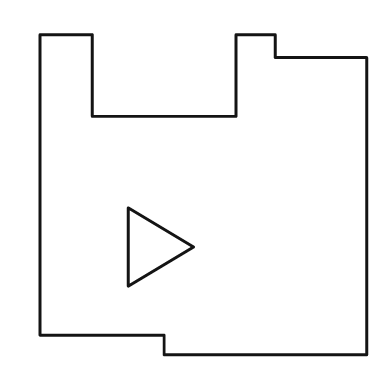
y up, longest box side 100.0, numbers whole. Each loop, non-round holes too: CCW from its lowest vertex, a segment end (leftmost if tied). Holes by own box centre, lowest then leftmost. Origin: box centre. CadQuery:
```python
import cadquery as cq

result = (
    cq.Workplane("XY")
    .moveTo(-12.0, -49.0)
    .lineTo(50.0, -49.0)
    .lineTo(50.0, 42.0)
    .lineTo(22.0, 42.0)
    .lineTo(22.0, 49.0)
    .lineTo(10.0, 49.0)
    .lineTo(10.0, 24.0)
    .lineTo(-34.0, 24.0)
    .lineTo(-34.0, 49.0)
    .lineTo(-50.0, 49.0)
    .lineTo(-50.0, -43.0)
    .lineTo(-12.0, -43.0)
    .close()
    .moveTo(-23.0, -28.0)
    .lineTo(-3.0, -16.0)
    .lineTo(-23.0, -4.0)
    .close()
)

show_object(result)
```